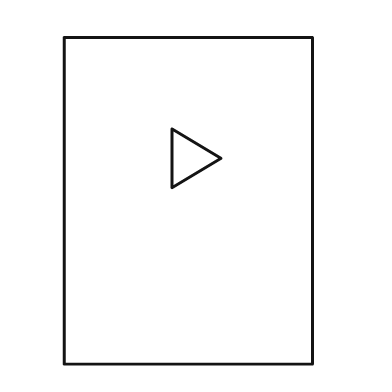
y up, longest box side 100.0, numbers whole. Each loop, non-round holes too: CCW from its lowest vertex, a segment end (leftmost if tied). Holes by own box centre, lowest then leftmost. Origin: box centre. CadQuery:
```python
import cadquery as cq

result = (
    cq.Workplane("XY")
    .moveTo(-38.0, -50.0)
    .lineTo(38.0, -50.0)
    .lineTo(38.0, 50.0)
    .lineTo(-38.0, 50.0)
    .close()
    .moveTo(-5.0, 4.0)
    .lineTo(10.0, 13.0)
    .lineTo(-5.0, 22.0)
    .close()
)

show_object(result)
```